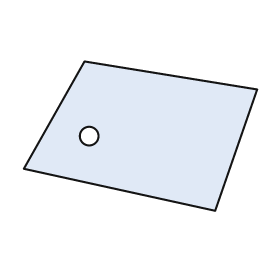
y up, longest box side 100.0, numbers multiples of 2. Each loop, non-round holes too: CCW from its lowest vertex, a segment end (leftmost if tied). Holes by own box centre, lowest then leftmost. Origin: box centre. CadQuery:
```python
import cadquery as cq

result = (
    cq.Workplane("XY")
    .moveTo(32.0, -32.0)
    .lineTo(50.0, 20.0)
    .lineTo(-24.0, 32.0)
    .lineTo(-50.0, -14.0)
    .close()
    .moveTo(-22.0, 0.0)
    .circle(4.0)
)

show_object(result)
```